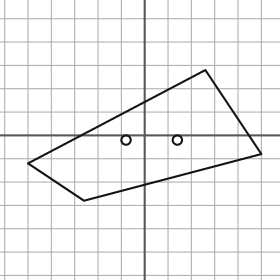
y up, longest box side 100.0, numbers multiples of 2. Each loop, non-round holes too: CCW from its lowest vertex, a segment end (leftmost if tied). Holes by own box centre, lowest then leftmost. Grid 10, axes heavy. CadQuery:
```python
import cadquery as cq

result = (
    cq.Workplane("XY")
    .moveTo(-26.0, -28.0)
    .lineTo(50.0, -8.0)
    .lineTo(26.0, 28.0)
    .lineTo(-50.0, -12.0)
    .close()
    .moveTo(-8.0, -2.0)
    .circle(2.0)
    .moveTo(14.0, -2.0)
    .circle(2.0)
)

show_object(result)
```